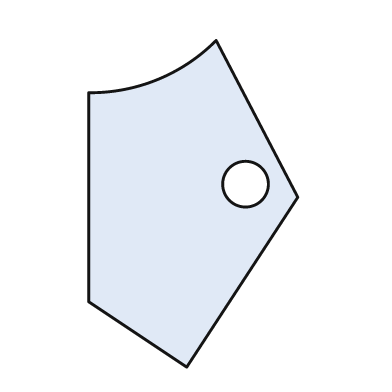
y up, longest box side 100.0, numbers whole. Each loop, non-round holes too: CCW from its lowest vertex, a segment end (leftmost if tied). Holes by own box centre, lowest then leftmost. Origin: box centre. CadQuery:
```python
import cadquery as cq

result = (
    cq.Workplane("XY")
    .moveTo(-2.0, -50.0)
    .lineTo(32.0, 2.0)
    .lineTo(7.0, 50.0)
    .threePointArc((-11.0, 38.0), (-32.0, 34.0))
    .lineTo(-32.0, -30.0)
    .close()
    .moveTo(16.0, 6.0)
    .circle(7.0)
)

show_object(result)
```